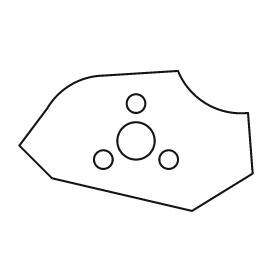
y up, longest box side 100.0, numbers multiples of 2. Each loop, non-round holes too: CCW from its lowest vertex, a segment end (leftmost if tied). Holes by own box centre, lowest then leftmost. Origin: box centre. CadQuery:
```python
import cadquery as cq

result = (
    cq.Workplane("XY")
    .moveTo(24.0, -30.0)
    .lineTo(50.0, -14.0)
    .lineTo(48.0, 12.0)
    .threePointArc((30.0, 16.0), (18.0, 30.0))
    .lineTo(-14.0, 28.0)
    .threePointArc((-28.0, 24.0), (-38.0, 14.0))
    .lineTo(-50.0, -2.0)
    .lineTo(-36.0, -16.0)
    .close()
    .moveTo(-14.0, -8.0)
    .circle(4.0)
    .moveTo(14.0, -8.0)
    .circle(4.0)
    .moveTo(0.0, 0.0)
    .circle(8.0)
    .moveTo(0.0, 16.0)
    .circle(4.0)
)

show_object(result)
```